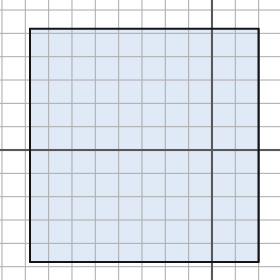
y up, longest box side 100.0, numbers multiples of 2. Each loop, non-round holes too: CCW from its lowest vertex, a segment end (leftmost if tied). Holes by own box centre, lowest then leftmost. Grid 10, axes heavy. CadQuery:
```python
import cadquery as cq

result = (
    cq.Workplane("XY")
    .moveTo(-78.0, -48.0)
    .lineTo(20.0, -48.0)
    .lineTo(20.0, 52.0)
    .lineTo(-78.0, 52.0)
    .close()
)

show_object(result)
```